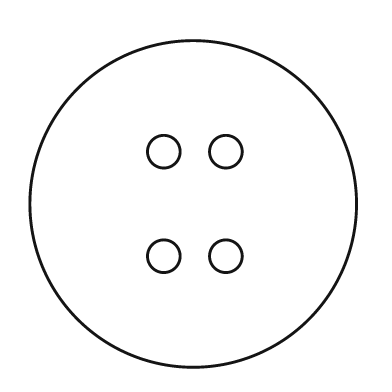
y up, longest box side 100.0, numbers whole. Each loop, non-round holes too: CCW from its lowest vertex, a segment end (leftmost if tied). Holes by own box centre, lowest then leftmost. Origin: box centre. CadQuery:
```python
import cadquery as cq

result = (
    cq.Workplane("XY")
    .moveTo(0.0, 0.0)
    .circle(50.0)
    .moveTo(-9.0, -16.0)
    .circle(5.0)
    .moveTo(10.0, -16.0)
    .circle(5.0)
    .moveTo(-9.0, 16.0)
    .circle(5.0)
    .moveTo(10.0, 16.0)
    .circle(5.0)
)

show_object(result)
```